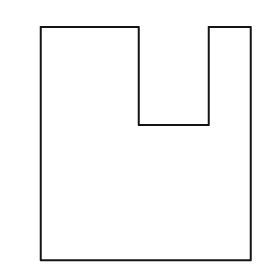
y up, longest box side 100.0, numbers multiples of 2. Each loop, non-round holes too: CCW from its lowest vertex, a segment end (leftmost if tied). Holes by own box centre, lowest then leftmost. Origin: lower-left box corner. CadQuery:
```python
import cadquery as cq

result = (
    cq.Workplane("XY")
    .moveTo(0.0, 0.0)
    .lineTo(90.0, 0.0)
    .lineTo(90.0, 100.0)
    .lineTo(72.0, 100.0)
    .lineTo(72.0, 58.0)
    .lineTo(42.0, 58.0)
    .lineTo(42.0, 100.0)
    .lineTo(0.0, 100.0)
    .close()
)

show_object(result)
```